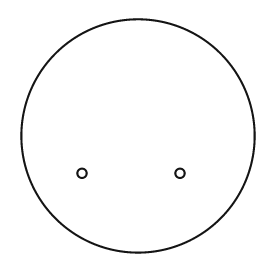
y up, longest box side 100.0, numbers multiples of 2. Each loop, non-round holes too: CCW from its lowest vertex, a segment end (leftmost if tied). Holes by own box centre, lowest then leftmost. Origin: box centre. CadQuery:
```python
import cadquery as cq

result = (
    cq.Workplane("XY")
    .moveTo(0.0, 0.0)
    .circle(50.0)
    .moveTo(-24.0, -16.0)
    .circle(2.0)
    .moveTo(18.0, -16.0)
    .circle(2.0)
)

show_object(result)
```